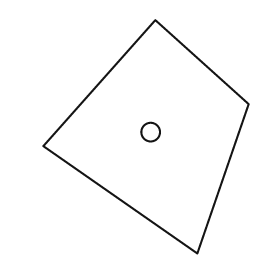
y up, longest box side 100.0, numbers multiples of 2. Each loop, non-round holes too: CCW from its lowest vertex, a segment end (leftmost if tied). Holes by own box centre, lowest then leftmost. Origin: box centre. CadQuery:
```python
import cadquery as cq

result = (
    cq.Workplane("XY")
    .moveTo(22.0, -50.0)
    .lineTo(44.0, 14.0)
    .lineTo(4.0, 50.0)
    .lineTo(-44.0, -4.0)
    .close()
    .moveTo(2.0, 2.0)
    .circle(4.0)
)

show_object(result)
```